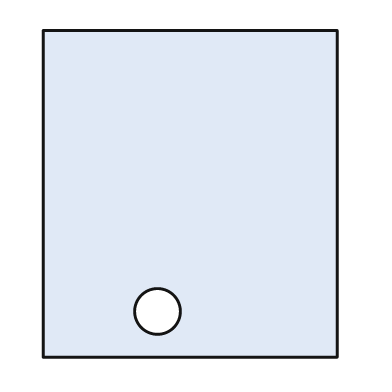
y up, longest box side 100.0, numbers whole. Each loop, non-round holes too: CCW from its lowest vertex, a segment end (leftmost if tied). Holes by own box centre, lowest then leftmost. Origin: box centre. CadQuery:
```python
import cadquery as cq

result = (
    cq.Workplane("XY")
    .moveTo(-45.0, -50.0)
    .lineTo(45.0, -50.0)
    .lineTo(45.0, 50.0)
    .lineTo(-45.0, 50.0)
    .close()
    .moveTo(-10.0, -36.0)
    .circle(7.0)
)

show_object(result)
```